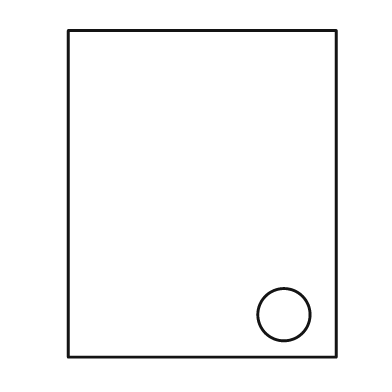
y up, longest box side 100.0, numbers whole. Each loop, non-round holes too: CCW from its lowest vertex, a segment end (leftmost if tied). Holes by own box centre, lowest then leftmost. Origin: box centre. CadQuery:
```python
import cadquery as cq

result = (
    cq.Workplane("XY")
    .moveTo(-41.0, -50.0)
    .lineTo(41.0, -50.0)
    .lineTo(41.0, 50.0)
    .lineTo(-41.0, 50.0)
    .close()
    .moveTo(25.0, -37.0)
    .circle(8.0)
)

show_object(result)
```